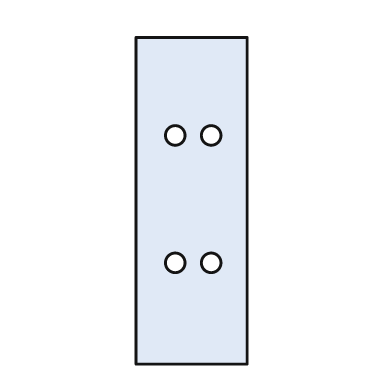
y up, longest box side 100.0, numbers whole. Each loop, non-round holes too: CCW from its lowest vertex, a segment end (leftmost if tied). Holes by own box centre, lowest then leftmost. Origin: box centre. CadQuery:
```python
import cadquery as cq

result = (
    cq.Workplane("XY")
    .moveTo(-17.0, -50.0)
    .lineTo(17.0, -50.0)
    .lineTo(17.0, 50.0)
    .lineTo(-17.0, 50.0)
    .close()
    .moveTo(-5.0, -19.0)
    .circle(3.0)
    .moveTo(6.0, -19.0)
    .circle(3.0)
    .moveTo(-5.0, 20.0)
    .circle(3.0)
    .moveTo(6.0, 20.0)
    .circle(3.0)
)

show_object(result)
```